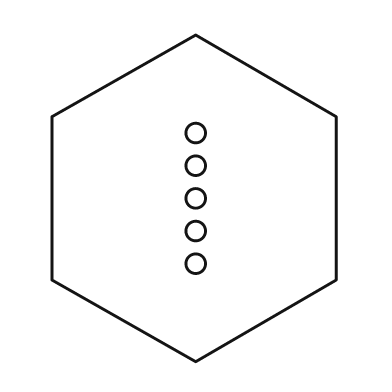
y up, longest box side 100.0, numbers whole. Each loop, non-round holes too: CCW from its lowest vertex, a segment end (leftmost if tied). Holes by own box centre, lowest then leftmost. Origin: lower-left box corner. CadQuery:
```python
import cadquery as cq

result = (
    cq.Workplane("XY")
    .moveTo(44.0, 0.0)
    .lineTo(87.0, 25.0)
    .lineTo(87.0, 75.0)
    .lineTo(44.0, 100.0)
    .lineTo(0.0, 75.0)
    .lineTo(0.0, 25.0)
    .close()
    .moveTo(44.0, 30.0)
    .circle(3.0)
    .moveTo(44.0, 40.0)
    .circle(3.0)
    .moveTo(44.0, 50.0)
    .circle(3.0)
    .moveTo(44.0, 60.0)
    .circle(3.0)
    .moveTo(44.0, 70.0)
    .circle(3.0)
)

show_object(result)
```